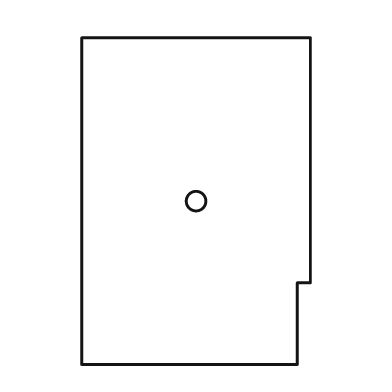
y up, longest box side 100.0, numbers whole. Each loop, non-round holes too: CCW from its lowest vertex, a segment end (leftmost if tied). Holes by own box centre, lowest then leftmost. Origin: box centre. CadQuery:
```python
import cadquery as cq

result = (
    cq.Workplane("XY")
    .moveTo(-35.0, -50.0)
    .lineTo(31.0, -50.0)
    .lineTo(31.0, -25.0)
    .lineTo(35.0, -25.0)
    .lineTo(35.0, 50.0)
    .lineTo(-35.0, 50.0)
    .close()
    .moveTo(0.0, 0.0)
    .circle(3.0)
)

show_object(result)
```